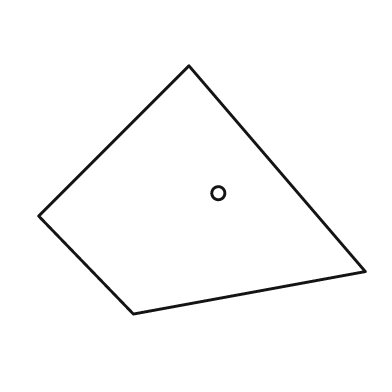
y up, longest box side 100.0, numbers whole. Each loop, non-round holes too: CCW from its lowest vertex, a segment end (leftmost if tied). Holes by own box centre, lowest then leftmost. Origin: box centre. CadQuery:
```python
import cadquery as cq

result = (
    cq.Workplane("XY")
    .moveTo(-21.0, -38.0)
    .lineTo(50.0, -25.0)
    .lineTo(-4.0, 38.0)
    .lineTo(-50.0, -8.0)
    .close()
    .moveTo(5.0, -1.0)
    .circle(2.0)
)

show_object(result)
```